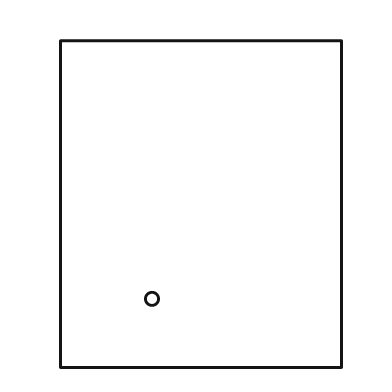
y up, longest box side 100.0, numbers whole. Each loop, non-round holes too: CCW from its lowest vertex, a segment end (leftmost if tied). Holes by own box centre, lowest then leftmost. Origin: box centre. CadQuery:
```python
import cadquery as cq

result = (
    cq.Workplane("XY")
    .moveTo(-43.0, -50.0)
    .lineTo(43.0, -50.0)
    .lineTo(43.0, 50.0)
    .lineTo(-43.0, 50.0)
    .close()
    .moveTo(-15.0, -29.0)
    .circle(2.0)
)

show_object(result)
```